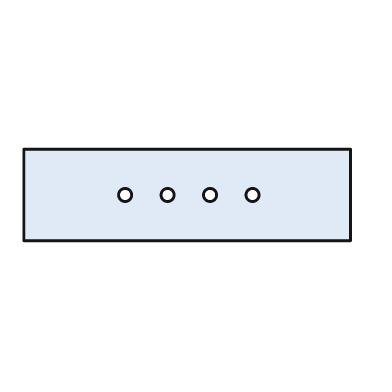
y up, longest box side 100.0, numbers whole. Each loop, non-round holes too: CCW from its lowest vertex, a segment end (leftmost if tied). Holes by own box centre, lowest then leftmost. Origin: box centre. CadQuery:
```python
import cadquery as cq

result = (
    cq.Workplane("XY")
    .moveTo(-50.0, -14.0)
    .lineTo(50.0, -14.0)
    .lineTo(50.0, 14.0)
    .lineTo(-50.0, 14.0)
    .close()
    .moveTo(-19.0, 0.0)
    .circle(2.0)
    .moveTo(-6.0, 0.0)
    .circle(2.0)
    .moveTo(7.0, 0.0)
    .circle(2.0)
    .moveTo(20.0, 0.0)
    .circle(2.0)
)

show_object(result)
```